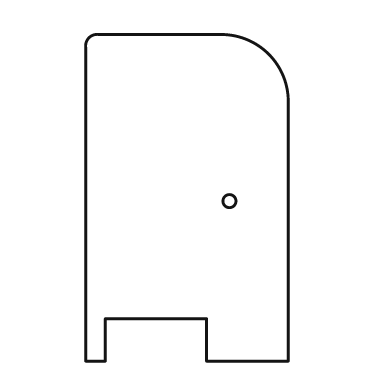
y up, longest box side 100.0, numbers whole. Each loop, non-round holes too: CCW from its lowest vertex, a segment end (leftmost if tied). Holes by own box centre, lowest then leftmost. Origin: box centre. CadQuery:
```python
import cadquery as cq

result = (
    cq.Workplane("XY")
    .moveTo(-31.0, -50.0)
    .lineTo(-25.0, -50.0)
    .lineTo(-25.0, -37.0)
    .lineTo(6.0, -37.0)
    .lineTo(6.0, -50.0)
    .lineTo(31.0, -50.0)
    .lineTo(31.0, 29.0)
    .threePointArc((25.0, 44.0), (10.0, 50.0))
    .lineTo(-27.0, 50.0)
    .threePointArc((-30.0, 49.0), (-31.0, 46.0))
    .close()
    .moveTo(13.0, -1.0)
    .circle(2.0)
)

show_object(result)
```